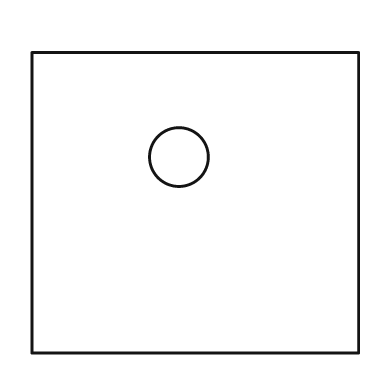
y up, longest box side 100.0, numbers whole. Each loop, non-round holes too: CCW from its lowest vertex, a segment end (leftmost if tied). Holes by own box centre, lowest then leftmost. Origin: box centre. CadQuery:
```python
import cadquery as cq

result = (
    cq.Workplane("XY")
    .moveTo(-50.0, -46.0)
    .lineTo(50.0, -46.0)
    .lineTo(50.0, 46.0)
    .lineTo(-50.0, 46.0)
    .close()
    .moveTo(-5.0, 14.0)
    .circle(9.0)
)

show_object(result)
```